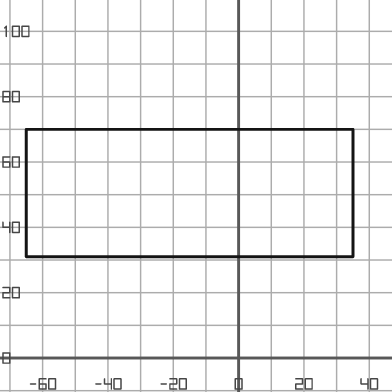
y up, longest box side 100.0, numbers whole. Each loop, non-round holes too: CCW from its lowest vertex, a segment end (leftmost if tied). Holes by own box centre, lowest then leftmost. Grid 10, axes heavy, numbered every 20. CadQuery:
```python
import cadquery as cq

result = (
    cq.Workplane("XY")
    .moveTo(-65.0, 31.0)
    .lineTo(35.0, 31.0)
    .lineTo(35.0, 70.0)
    .lineTo(-65.0, 70.0)
    .close()
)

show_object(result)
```